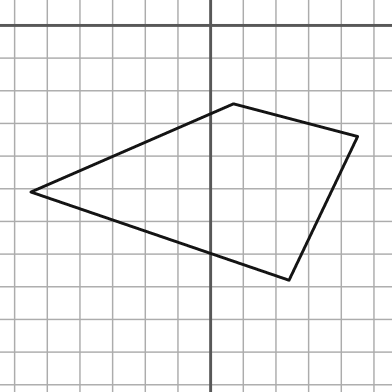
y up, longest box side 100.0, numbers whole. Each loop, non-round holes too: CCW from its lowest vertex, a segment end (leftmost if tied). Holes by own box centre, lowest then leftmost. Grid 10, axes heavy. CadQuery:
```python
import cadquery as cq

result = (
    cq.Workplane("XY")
    .moveTo(24.0, -78.0)
    .lineTo(45.0, -34.0)
    .lineTo(7.0, -24.0)
    .lineTo(-55.0, -51.0)
    .close()
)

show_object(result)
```